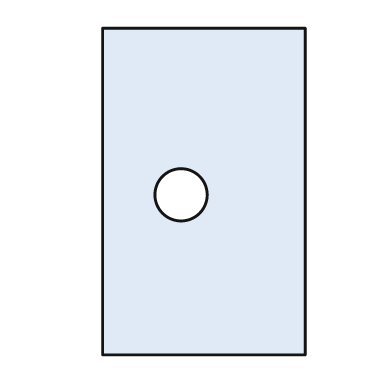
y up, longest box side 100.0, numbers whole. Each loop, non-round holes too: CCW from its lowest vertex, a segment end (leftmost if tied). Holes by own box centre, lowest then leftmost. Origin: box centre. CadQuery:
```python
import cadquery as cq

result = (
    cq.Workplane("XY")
    .moveTo(-31.0, -50.0)
    .lineTo(31.0, -50.0)
    .lineTo(31.0, 50.0)
    .lineTo(-31.0, 50.0)
    .close()
    .moveTo(-7.0, -1.0)
    .circle(8.0)
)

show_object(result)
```